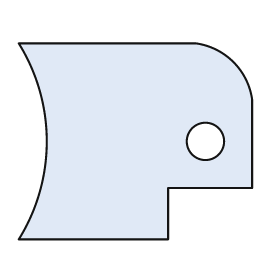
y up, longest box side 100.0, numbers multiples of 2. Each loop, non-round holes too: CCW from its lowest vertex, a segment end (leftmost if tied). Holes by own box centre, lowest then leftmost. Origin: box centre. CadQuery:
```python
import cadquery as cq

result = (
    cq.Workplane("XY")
    .moveTo(-50.0, -42.0)
    .lineTo(14.0, -42.0)
    .lineTo(14.0, -20.0)
    .lineTo(50.0, -20.0)
    .lineTo(50.0, 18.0)
    .threePointArc((42.0, 34.0), (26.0, 42.0))
    .lineTo(-50.0, 42.0)
    .threePointArc((-38.0, 0.0), (-50.0, -42.0))
    .close()
    .moveTo(30.0, 0.0)
    .circle(8.0)
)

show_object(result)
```